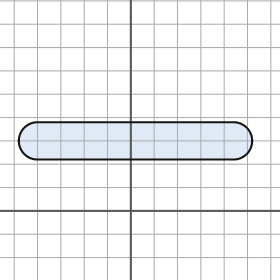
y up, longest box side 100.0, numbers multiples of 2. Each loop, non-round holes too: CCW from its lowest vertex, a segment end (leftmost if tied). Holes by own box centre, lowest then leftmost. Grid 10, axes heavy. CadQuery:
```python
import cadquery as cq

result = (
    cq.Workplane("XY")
    .moveTo(-40.0, 22.0)
    .lineTo(44.0, 22.0)
    .threePointArc((52.0, 30.0), (44.0, 38.0))
    .lineTo(-40.0, 38.0)
    .threePointArc((-48.0, 30.0), (-40.0, 22.0))
    .close()
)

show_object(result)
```